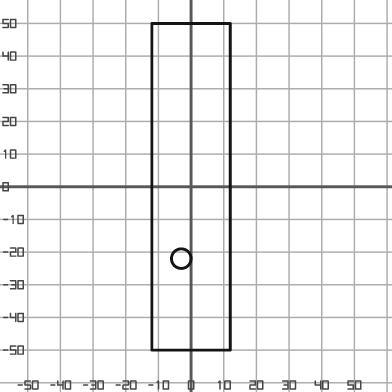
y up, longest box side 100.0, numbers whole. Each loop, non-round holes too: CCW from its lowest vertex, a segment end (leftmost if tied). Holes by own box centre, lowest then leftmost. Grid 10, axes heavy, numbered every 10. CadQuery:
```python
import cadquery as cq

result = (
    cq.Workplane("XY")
    .moveTo(-12.0, -50.0)
    .lineTo(12.0, -50.0)
    .lineTo(12.0, 50.0)
    .lineTo(-12.0, 50.0)
    .close()
    .moveTo(-3.0, -22.0)
    .circle(3.0)
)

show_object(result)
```